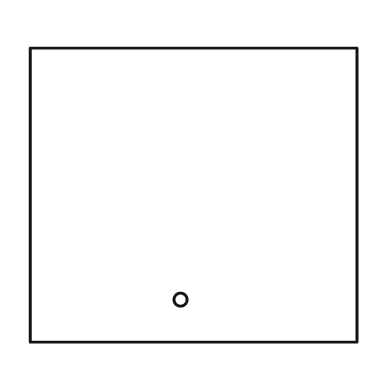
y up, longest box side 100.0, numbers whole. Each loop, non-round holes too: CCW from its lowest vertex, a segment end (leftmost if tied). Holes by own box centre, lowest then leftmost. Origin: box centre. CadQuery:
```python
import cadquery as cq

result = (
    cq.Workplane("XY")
    .moveTo(-50.0, -45.0)
    .lineTo(50.0, -45.0)
    .lineTo(50.0, 45.0)
    .lineTo(-50.0, 45.0)
    .close()
    .moveTo(-4.0, -32.0)
    .circle(2.0)
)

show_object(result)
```